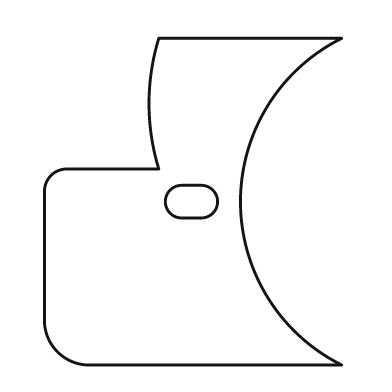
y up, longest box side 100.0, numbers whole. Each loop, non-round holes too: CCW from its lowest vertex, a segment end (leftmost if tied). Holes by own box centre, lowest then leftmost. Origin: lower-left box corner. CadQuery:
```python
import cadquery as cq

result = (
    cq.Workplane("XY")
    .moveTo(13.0, 0.0)
    .lineTo(91.0, 0.0)
    .threePointArc((60.0, 50.0), (91.0, 100.0))
    .lineTo(35.0, 100.0)
    .threePointArc((32.0, 80.0), (35.0, 60.0))
    .lineTo(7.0, 60.0)
    .threePointArc((2.0, 58.0), (0.0, 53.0))
    .lineTo(0.0, 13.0)
    .threePointArc((4.0, 4.0), (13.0, 0.0))
    .close()
    .moveTo(42.0, 45.0)
    .lineTo(48.0, 45.0)
    .threePointArc((53.0, 50.0), (48.0, 55.0))
    .lineTo(42.0, 55.0)
    .threePointArc((37.0, 50.0), (42.0, 45.0))
    .close()
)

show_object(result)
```